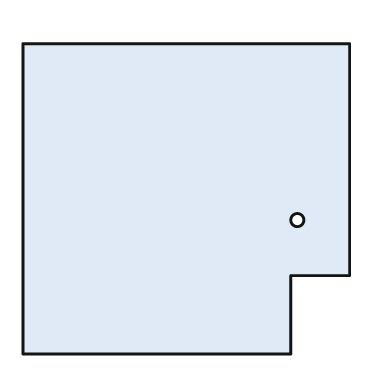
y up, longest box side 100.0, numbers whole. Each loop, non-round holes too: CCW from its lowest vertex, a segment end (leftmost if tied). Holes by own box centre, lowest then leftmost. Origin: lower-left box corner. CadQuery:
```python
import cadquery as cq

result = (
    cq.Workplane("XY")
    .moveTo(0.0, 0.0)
    .lineTo(82.0, 0.0)
    .lineTo(82.0, 24.0)
    .lineTo(100.0, 24.0)
    .lineTo(100.0, 95.0)
    .lineTo(0.0, 95.0)
    .close()
    .moveTo(84.0, 41.0)
    .circle(2.0)
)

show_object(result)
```